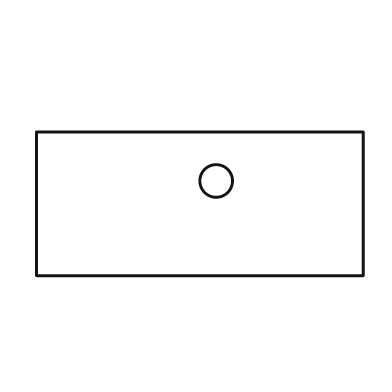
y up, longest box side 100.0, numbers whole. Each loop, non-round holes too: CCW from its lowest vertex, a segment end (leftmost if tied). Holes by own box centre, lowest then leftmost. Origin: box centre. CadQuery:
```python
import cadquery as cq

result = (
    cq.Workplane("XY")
    .moveTo(-50.0, -22.0)
    .lineTo(50.0, -22.0)
    .lineTo(50.0, 22.0)
    .lineTo(-50.0, 22.0)
    .close()
    .moveTo(5.0, 7.0)
    .circle(5.0)
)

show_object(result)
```